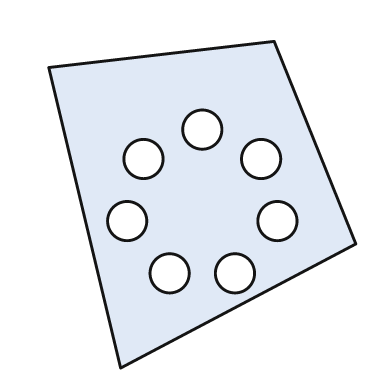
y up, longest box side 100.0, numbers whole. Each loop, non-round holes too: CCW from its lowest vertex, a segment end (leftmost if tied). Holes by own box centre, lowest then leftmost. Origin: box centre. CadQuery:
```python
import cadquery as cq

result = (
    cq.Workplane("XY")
    .moveTo(-25.0, -50.0)
    .lineTo(47.0, -12.0)
    .lineTo(22.0, 50.0)
    .lineTo(-47.0, 42.0)
    .close()
    .moveTo(-10.0, -21.0)
    .circle(6.0)
    .moveTo(10.0, -21.0)
    .circle(6.0)
    .moveTo(-23.0, -5.0)
    .circle(6.0)
    .moveTo(23.0, -5.0)
    .circle(6.0)
    .moveTo(-18.0, 14.0)
    .circle(6.0)
    .moveTo(18.0, 14.0)
    .circle(6.0)
    .moveTo(0.0, 23.0)
    .circle(6.0)
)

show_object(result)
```